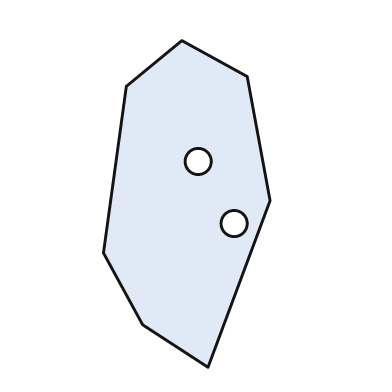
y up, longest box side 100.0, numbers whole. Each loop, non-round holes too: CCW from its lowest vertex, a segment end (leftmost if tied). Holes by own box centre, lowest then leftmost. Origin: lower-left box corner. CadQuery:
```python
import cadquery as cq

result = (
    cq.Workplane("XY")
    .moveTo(32.0, 0.0)
    .lineTo(51.0, 51.0)
    .lineTo(44.0, 89.0)
    .lineTo(24.0, 100.0)
    .lineTo(7.0, 86.0)
    .lineTo(0.0, 35.0)
    .lineTo(12.0, 13.0)
    .close()
    .moveTo(40.0, 44.0)
    .circle(4.0)
    .moveTo(29.0, 63.0)
    .circle(4.0)
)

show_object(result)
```